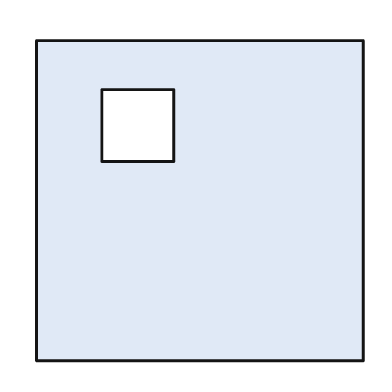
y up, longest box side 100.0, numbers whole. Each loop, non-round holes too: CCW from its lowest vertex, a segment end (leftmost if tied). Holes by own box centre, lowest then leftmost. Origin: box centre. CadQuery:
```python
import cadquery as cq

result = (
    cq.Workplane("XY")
    .moveTo(-50.0, -49.0)
    .lineTo(50.0, -49.0)
    .lineTo(50.0, 49.0)
    .lineTo(-50.0, 49.0)
    .close()
    .moveTo(-30.0, 12.0)
    .lineTo(-8.0, 12.0)
    .lineTo(-8.0, 34.0)
    .lineTo(-30.0, 34.0)
    .close()
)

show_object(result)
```